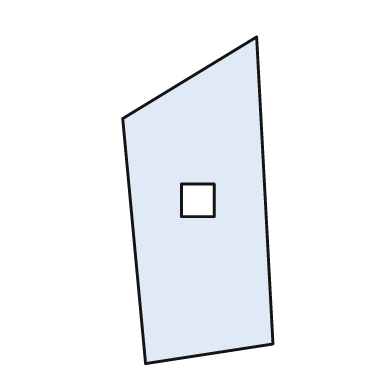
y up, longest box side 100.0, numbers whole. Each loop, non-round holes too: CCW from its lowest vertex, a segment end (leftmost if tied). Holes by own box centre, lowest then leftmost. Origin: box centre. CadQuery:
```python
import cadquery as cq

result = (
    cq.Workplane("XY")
    .moveTo(-16.0, -50.0)
    .lineTo(23.0, -44.0)
    .lineTo(18.0, 50.0)
    .lineTo(-23.0, 25.0)
    .close()
    .moveTo(-5.0, -5.0)
    .lineTo(5.0, -5.0)
    .lineTo(5.0, 5.0)
    .lineTo(-5.0, 5.0)
    .close()
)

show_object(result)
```